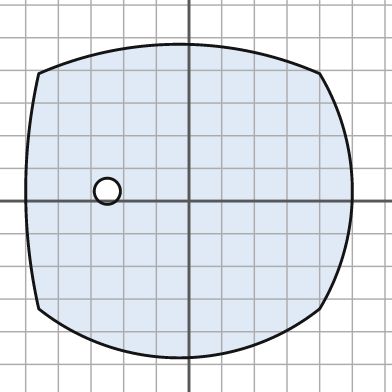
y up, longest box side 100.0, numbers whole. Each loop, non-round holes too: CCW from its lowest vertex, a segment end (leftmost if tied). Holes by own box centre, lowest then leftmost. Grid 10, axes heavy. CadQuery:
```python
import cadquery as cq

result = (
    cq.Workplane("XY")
    .moveTo(-46.0, -33.0)
    .threePointArc((-3.0, -48.0), (40.0, -33.0))
    .threePointArc((50.0, 3.0), (40.0, 39.0))
    .threePointArc((-3.0, 48.0), (-46.0, 39.0))
    .threePointArc((-50.0, 3.0), (-46.0, -33.0))
    .close()
    .moveTo(-25.0, 3.0)
    .circle(4.0)
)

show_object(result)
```